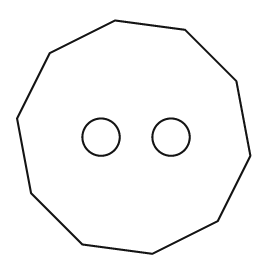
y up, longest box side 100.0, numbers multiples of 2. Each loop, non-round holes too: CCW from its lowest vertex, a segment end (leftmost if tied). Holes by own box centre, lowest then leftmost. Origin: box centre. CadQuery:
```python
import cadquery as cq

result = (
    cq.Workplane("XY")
    .moveTo(8.0, -50.0)
    .lineTo(36.0, -36.0)
    .lineTo(50.0, -8.0)
    .lineTo(44.0, 24.0)
    .lineTo(22.0, 46.0)
    .lineTo(-8.0, 50.0)
    .lineTo(-36.0, 36.0)
    .lineTo(-50.0, 8.0)
    .lineTo(-44.0, -24.0)
    .lineTo(-22.0, -46.0)
    .close()
    .moveTo(-14.0, 0.0)
    .circle(8.0)
    .moveTo(16.0, 0.0)
    .circle(8.0)
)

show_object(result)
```